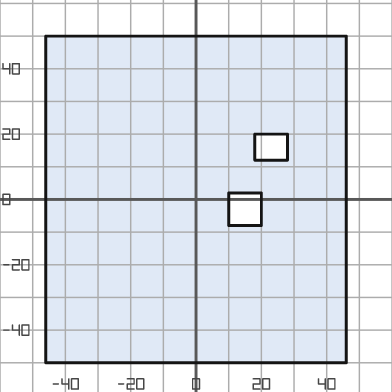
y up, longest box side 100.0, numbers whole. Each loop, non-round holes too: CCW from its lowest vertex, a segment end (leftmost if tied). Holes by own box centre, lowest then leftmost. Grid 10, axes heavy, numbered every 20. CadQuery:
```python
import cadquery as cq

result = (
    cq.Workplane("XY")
    .moveTo(-46.0, -50.0)
    .lineTo(46.0, -50.0)
    .lineTo(46.0, 50.0)
    .lineTo(-46.0, 50.0)
    .close()
    .moveTo(10.0, -8.0)
    .lineTo(20.0, -8.0)
    .lineTo(20.0, 2.0)
    .lineTo(10.0, 2.0)
    .close()
    .moveTo(18.0, 12.0)
    .lineTo(28.0, 12.0)
    .lineTo(28.0, 20.0)
    .lineTo(18.0, 20.0)
    .close()
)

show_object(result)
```